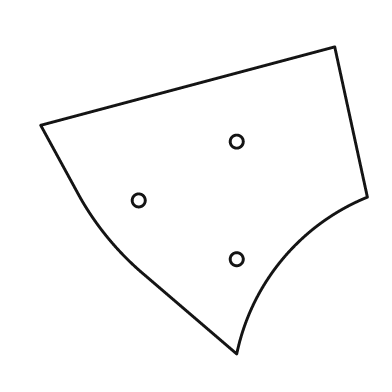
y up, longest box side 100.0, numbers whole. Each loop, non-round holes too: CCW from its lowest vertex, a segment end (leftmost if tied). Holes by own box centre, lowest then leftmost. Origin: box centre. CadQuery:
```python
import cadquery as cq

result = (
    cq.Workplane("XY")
    .moveTo(10.0, -47.0)
    .threePointArc((24.0, -18.0), (50.0, 1.0))
    .lineTo(40.0, 47.0)
    .lineTo(-50.0, 23.0)
    .lineTo(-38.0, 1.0)
    .threePointArc((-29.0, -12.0), (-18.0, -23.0))
    .close()
    .moveTo(10.0, -18.0)
    .circle(2.0)
    .moveTo(-20.0, 0.0)
    .circle(2.0)
    .moveTo(10.0, 18.0)
    .circle(2.0)
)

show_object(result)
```